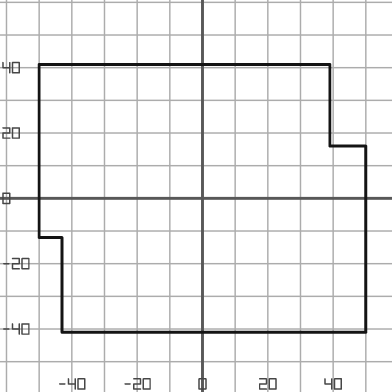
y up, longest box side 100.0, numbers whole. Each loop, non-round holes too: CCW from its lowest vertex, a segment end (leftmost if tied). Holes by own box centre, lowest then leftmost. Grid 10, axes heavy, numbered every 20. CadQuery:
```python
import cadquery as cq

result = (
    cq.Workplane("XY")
    .moveTo(-43.0, -41.0)
    .lineTo(50.0, -41.0)
    .lineTo(50.0, 16.0)
    .lineTo(39.0, 16.0)
    .lineTo(39.0, 41.0)
    .lineTo(-50.0, 41.0)
    .lineTo(-50.0, -12.0)
    .lineTo(-43.0, -12.0)
    .close()
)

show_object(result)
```